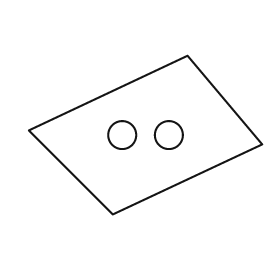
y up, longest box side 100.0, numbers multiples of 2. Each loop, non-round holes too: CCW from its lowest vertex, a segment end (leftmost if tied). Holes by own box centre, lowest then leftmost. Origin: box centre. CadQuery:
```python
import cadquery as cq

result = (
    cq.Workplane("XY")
    .moveTo(-14.0, -34.0)
    .lineTo(50.0, -4.0)
    .lineTo(18.0, 34.0)
    .lineTo(-50.0, 2.0)
    .close()
    .moveTo(-10.0, 0.0)
    .circle(6.0)
    .moveTo(10.0, 0.0)
    .circle(6.0)
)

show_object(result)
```